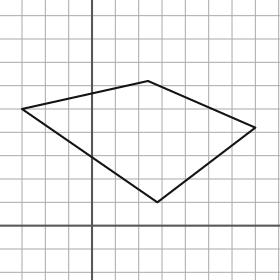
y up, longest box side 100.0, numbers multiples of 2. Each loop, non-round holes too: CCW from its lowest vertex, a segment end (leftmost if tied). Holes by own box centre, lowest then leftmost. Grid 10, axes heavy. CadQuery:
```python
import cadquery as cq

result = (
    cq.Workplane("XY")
    .moveTo(28.0, 10.0)
    .lineTo(70.0, 42.0)
    .lineTo(24.0, 62.0)
    .lineTo(-30.0, 50.0)
    .close()
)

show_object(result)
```